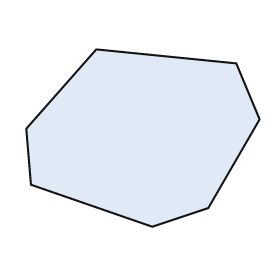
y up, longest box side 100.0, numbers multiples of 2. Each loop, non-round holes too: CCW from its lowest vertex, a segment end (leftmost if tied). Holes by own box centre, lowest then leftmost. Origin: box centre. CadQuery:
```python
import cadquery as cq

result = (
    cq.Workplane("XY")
    .moveTo(4.0, -38.0)
    .lineTo(28.0, -30.0)
    .lineTo(50.0, 8.0)
    .lineTo(40.0, 32.0)
    .lineTo(-20.0, 38.0)
    .lineTo(-50.0, 4.0)
    .lineTo(-48.0, -20.0)
    .close()
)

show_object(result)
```